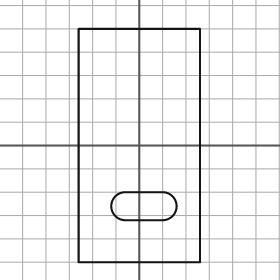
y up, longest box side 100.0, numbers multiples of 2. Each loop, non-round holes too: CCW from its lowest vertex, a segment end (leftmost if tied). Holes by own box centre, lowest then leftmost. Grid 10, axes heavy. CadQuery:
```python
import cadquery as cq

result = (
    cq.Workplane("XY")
    .moveTo(-26.0, -50.0)
    .lineTo(26.0, -50.0)
    .lineTo(26.0, 50.0)
    .lineTo(-26.0, 50.0)
    .close()
    .moveTo(-6.0, -32.0)
    .lineTo(10.0, -32.0)
    .threePointArc((16.0, -26.0), (10.0, -20.0))
    .lineTo(-6.0, -20.0)
    .threePointArc((-12.0, -26.0), (-6.0, -32.0))
    .close()
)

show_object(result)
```